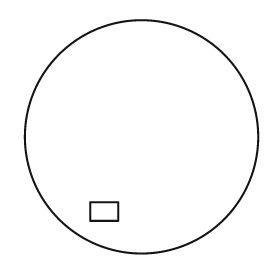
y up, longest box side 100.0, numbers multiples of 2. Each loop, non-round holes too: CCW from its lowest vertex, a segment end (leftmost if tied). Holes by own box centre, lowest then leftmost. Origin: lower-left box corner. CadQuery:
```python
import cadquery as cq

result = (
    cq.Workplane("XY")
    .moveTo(50.0, 50.0)
    .circle(50.0)
    .moveTo(28.0, 14.0)
    .lineTo(40.0, 14.0)
    .lineTo(40.0, 22.0)
    .lineTo(28.0, 22.0)
    .close()
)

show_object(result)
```